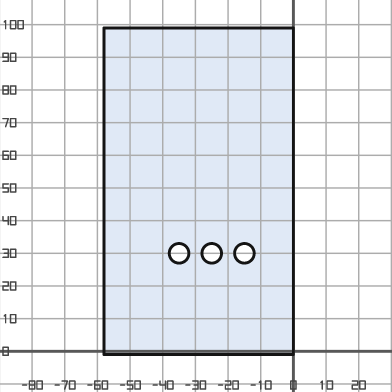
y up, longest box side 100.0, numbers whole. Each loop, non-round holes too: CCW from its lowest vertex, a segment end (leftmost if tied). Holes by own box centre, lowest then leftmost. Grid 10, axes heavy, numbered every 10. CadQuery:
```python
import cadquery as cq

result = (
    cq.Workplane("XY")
    .moveTo(-58.0, -1.0)
    .lineTo(0.0, -1.0)
    .lineTo(0.0, 99.0)
    .lineTo(-58.0, 99.0)
    .close()
    .moveTo(-35.0, 30.0)
    .circle(3.0)
    .moveTo(-25.0, 30.0)
    .circle(3.0)
    .moveTo(-15.0, 30.0)
    .circle(3.0)
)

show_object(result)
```